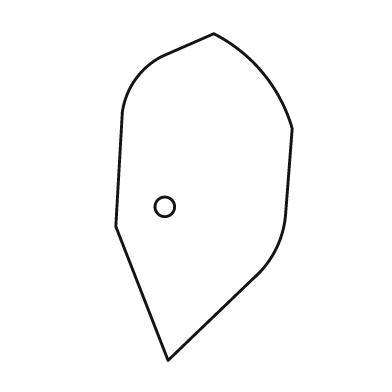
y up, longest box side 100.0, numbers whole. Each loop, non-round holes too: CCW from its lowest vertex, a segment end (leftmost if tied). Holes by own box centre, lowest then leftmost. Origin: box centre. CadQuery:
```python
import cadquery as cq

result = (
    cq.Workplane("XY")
    .moveTo(-11.0, -50.0)
    .lineTo(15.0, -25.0)
    .threePointArc((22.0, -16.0), (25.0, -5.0))
    .lineTo(27.0, 21.0)
    .threePointArc((18.0, 38.0), (3.0, 50.0))
    .lineTo(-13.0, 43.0)
    .threePointArc((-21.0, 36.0), (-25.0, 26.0))
    .lineTo(-27.0, -9.0)
    .close()
    .moveTo(-12.0, -3.0)
    .circle(3.0)
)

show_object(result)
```